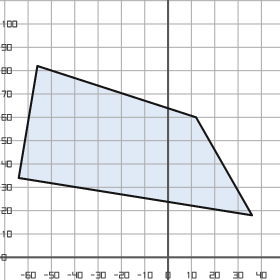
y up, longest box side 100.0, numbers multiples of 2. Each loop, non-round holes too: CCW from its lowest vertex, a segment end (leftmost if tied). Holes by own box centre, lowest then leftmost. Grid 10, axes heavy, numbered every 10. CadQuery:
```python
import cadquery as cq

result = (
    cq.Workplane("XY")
    .moveTo(36.0, 18.0)
    .lineTo(12.0, 60.0)
    .lineTo(-56.0, 82.0)
    .lineTo(-64.0, 34.0)
    .close()
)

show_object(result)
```